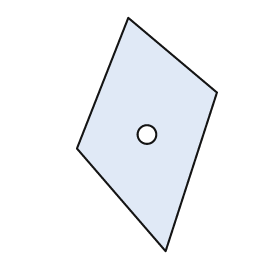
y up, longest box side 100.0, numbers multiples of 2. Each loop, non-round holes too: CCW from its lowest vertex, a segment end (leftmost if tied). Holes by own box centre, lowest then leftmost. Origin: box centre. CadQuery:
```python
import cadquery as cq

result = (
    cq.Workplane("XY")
    .moveTo(8.0, -50.0)
    .lineTo(30.0, 18.0)
    .lineTo(-8.0, 50.0)
    .lineTo(-30.0, -6.0)
    .close()
    .moveTo(0.0, 0.0)
    .circle(4.0)
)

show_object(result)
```